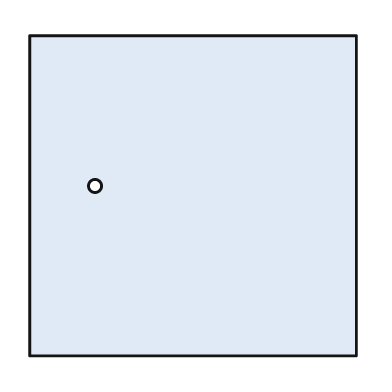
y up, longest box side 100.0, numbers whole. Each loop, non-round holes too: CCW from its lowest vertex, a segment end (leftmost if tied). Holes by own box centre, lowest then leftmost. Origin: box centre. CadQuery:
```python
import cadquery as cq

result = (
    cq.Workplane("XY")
    .moveTo(-50.0, -49.0)
    .lineTo(50.0, -49.0)
    .lineTo(50.0, 49.0)
    .lineTo(-50.0, 49.0)
    .close()
    .moveTo(-30.0, 3.0)
    .circle(2.0)
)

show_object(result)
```